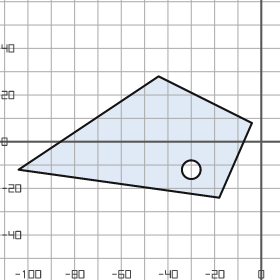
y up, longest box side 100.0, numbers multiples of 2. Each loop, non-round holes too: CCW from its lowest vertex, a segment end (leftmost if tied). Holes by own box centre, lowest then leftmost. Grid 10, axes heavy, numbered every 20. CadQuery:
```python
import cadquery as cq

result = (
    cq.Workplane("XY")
    .moveTo(-18.0, -24.0)
    .lineTo(-4.0, 8.0)
    .lineTo(-44.0, 28.0)
    .lineTo(-104.0, -12.0)
    .close()
    .moveTo(-30.0, -12.0)
    .circle(4.0)
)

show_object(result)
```